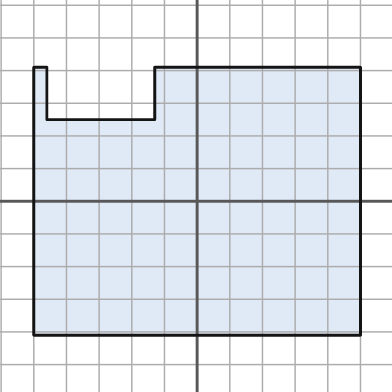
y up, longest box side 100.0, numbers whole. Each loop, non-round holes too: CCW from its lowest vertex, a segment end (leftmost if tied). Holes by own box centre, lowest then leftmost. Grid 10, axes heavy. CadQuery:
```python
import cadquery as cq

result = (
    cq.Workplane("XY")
    .moveTo(-50.0, -41.0)
    .lineTo(50.0, -41.0)
    .lineTo(50.0, 41.0)
    .lineTo(-13.0, 41.0)
    .lineTo(-13.0, 25.0)
    .lineTo(-46.0, 25.0)
    .lineTo(-46.0, 41.0)
    .lineTo(-50.0, 41.0)
    .close()
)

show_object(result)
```